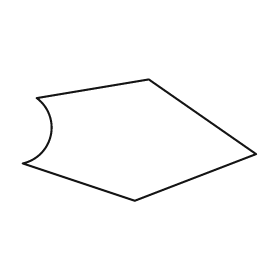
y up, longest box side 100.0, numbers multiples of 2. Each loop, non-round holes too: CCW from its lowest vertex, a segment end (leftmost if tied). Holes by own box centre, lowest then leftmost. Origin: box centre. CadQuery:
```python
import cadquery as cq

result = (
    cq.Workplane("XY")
    .moveTo(-2.0, -26.0)
    .lineTo(50.0, -6.0)
    .lineTo(4.0, 26.0)
    .lineTo(-44.0, 18.0)
    .threePointArc((-38.0, 2.0), (-50.0, -10.0))
    .close()
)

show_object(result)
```